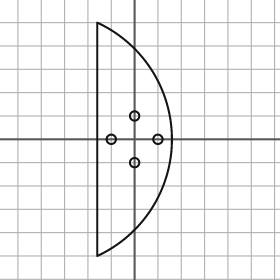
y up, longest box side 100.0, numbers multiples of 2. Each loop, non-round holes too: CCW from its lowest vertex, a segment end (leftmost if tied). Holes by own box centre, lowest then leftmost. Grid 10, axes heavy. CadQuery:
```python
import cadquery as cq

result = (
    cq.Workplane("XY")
    .moveTo(-16.0, -50.0)
    .threePointArc((16.0, 0.0), (-16.0, 50.0))
    .close()
    .moveTo(0.0, -10.0)
    .circle(2.0)
    .moveTo(-10.0, 0.0)
    .circle(2.0)
    .moveTo(10.0, 0.0)
    .circle(2.0)
    .moveTo(0.0, 10.0)
    .circle(2.0)
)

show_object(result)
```